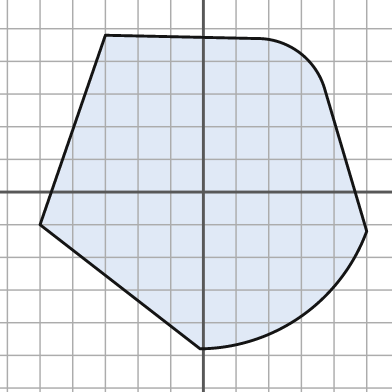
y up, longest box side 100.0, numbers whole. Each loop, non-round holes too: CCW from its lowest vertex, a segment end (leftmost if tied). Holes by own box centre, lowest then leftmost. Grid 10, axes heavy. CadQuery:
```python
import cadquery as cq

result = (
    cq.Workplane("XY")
    .moveTo(-1.0, -48.0)
    .threePointArc((30.0, -38.0), (50.0, -12.0))
    .lineTo(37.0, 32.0)
    .threePointArc((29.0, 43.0), (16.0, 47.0))
    .lineTo(-30.0, 48.0)
    .lineTo(-50.0, -10.0)
    .close()
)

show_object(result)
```